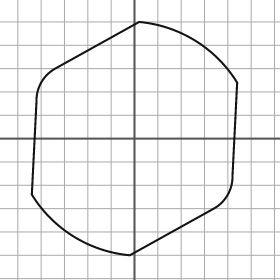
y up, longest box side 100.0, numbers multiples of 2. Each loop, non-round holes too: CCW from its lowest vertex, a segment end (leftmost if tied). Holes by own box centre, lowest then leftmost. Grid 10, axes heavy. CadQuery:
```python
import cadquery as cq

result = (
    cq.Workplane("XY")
    .moveTo(-2.0, -50.0)
    .lineTo(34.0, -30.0)
    .threePointArc((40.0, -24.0), (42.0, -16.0))
    .lineTo(44.0, 24.0)
    .threePointArc((26.0, 42.0), (2.0, 50.0))
    .lineTo(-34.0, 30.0)
    .threePointArc((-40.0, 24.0), (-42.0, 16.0))
    .lineTo(-44.0, -24.0)
    .threePointArc((-26.0, -42.0), (-2.0, -50.0))
    .close()
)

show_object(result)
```